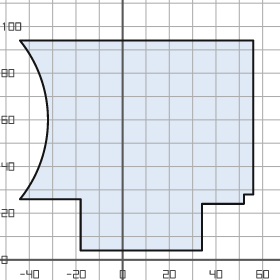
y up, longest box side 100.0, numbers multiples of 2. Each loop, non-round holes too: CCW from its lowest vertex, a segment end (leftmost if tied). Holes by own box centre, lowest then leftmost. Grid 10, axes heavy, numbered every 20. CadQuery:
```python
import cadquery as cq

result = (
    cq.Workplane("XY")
    .moveTo(-18.0, 4.0)
    .lineTo(34.0, 4.0)
    .lineTo(34.0, 24.0)
    .lineTo(52.0, 24.0)
    .lineTo(52.0, 28.0)
    .lineTo(56.0, 28.0)
    .lineTo(56.0, 94.0)
    .lineTo(-44.0, 94.0)
    .threePointArc((-32.0, 60.0), (-44.0, 26.0))
    .lineTo(-18.0, 26.0)
    .close()
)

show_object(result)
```